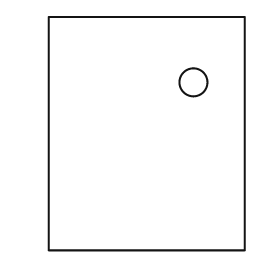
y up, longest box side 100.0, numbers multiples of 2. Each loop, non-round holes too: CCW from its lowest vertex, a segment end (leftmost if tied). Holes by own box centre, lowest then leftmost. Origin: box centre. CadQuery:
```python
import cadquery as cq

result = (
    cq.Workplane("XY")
    .moveTo(-42.0, -50.0)
    .lineTo(42.0, -50.0)
    .lineTo(42.0, 50.0)
    .lineTo(-42.0, 50.0)
    .close()
    .moveTo(20.0, 22.0)
    .circle(6.0)
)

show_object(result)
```